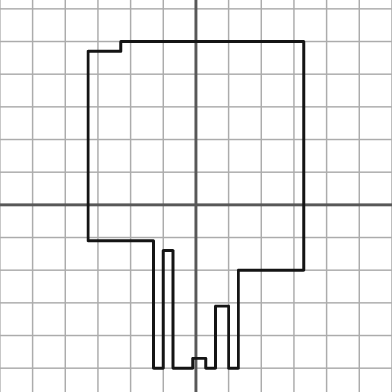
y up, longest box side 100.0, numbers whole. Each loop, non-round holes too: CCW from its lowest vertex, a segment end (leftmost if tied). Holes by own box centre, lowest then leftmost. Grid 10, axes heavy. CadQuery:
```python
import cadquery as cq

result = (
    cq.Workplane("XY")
    .moveTo(-13.0, -50.0)
    .lineTo(-10.0, -50.0)
    .lineTo(-10.0, -14.0)
    .lineTo(-7.0, -14.0)
    .lineTo(-7.0, -50.0)
    .lineTo(-1.0, -50.0)
    .lineTo(-1.0, -47.0)
    .lineTo(3.0, -47.0)
    .lineTo(3.0, -50.0)
    .lineTo(6.0, -50.0)
    .lineTo(6.0, -31.0)
    .lineTo(10.0, -31.0)
    .lineTo(10.0, -50.0)
    .lineTo(13.0, -50.0)
    .lineTo(13.0, -20.0)
    .lineTo(33.0, -20.0)
    .lineTo(33.0, 50.0)
    .lineTo(-23.0, 50.0)
    .lineTo(-23.0, 47.0)
    .lineTo(-33.0, 47.0)
    .lineTo(-33.0, -11.0)
    .lineTo(-13.0, -11.0)
    .close()
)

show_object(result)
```